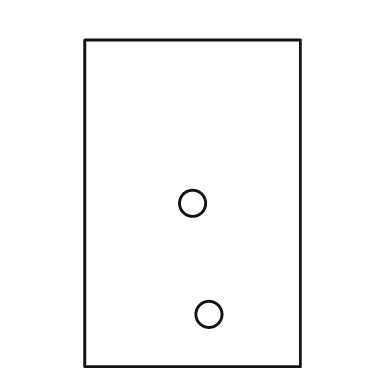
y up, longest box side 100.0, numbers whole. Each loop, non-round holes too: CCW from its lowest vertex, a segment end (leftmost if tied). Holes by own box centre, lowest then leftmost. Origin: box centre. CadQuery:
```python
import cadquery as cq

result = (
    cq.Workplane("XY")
    .moveTo(-33.0, -50.0)
    .lineTo(33.0, -50.0)
    .lineTo(33.0, 50.0)
    .lineTo(-33.0, 50.0)
    .close()
    .moveTo(5.0, -34.0)
    .circle(4.0)
    .moveTo(0.0, 0.0)
    .circle(4.0)
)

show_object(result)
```